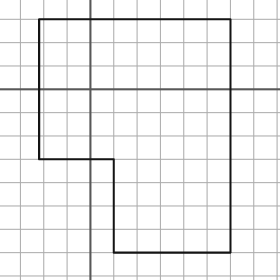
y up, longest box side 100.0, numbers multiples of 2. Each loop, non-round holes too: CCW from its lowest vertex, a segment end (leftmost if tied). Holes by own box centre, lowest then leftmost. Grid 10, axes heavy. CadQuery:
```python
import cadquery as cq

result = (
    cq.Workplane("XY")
    .moveTo(10.0, -70.0)
    .lineTo(60.0, -70.0)
    .lineTo(60.0, 30.0)
    .lineTo(-22.0, 30.0)
    .lineTo(-22.0, -30.0)
    .lineTo(10.0, -30.0)
    .close()
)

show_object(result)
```